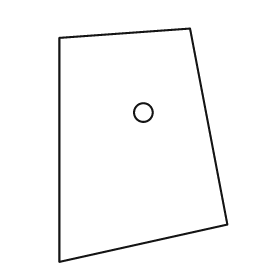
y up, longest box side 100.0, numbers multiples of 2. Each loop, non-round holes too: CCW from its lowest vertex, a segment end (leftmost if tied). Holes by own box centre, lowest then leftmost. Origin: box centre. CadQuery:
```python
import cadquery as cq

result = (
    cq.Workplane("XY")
    .moveTo(-36.0, -50.0)
    .lineTo(36.0, -34.0)
    .lineTo(20.0, 50.0)
    .lineTo(-36.0, 46.0)
    .close()
    .moveTo(0.0, 14.0)
    .circle(4.0)
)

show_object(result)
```